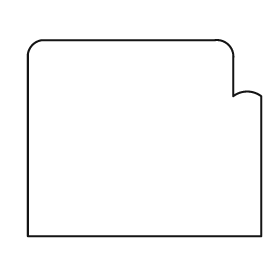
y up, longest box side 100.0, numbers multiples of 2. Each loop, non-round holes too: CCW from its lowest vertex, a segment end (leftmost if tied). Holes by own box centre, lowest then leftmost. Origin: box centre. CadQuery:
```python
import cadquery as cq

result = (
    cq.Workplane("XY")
    .moveTo(-50.0, -42.0)
    .lineTo(50.0, -42.0)
    .lineTo(50.0, 18.0)
    .threePointArc((44.0, 20.0), (38.0, 18.0))
    .lineTo(38.0, 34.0)
    .threePointArc((36.0, 40.0), (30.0, 42.0))
    .lineTo(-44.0, 42.0)
    .threePointArc((-48.0, 40.0), (-50.0, 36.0))
    .close()
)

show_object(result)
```